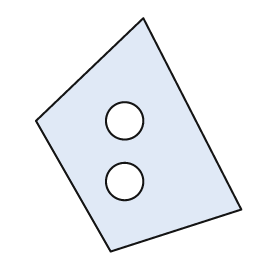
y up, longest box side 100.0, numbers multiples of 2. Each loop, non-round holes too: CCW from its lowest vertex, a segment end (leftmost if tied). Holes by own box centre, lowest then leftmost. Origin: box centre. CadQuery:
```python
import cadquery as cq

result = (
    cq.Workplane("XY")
    .moveTo(-12.0, -50.0)
    .lineTo(44.0, -32.0)
    .lineTo(2.0, 50.0)
    .lineTo(-44.0, 6.0)
    .close()
    .moveTo(-6.0, -20.0)
    .circle(8.0)
    .moveTo(-6.0, 6.0)
    .circle(8.0)
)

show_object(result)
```